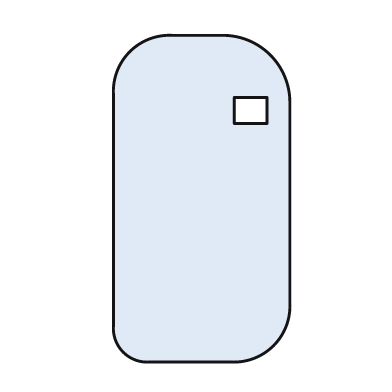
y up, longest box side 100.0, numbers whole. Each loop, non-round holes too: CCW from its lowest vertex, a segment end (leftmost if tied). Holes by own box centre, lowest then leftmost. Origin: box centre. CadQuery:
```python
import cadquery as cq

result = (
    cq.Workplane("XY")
    .moveTo(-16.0, -50.0)
    .lineTo(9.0, -50.0)
    .threePointArc((22.0, -45.0), (27.0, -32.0))
    .lineTo(27.0, 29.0)
    .threePointArc((21.0, 44.0), (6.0, 50.0))
    .lineTo(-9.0, 50.0)
    .threePointArc((-22.0, 45.0), (-27.0, 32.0))
    .lineTo(-27.0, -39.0)
    .threePointArc((-24.0, -47.0), (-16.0, -50.0))
    .close()
    .moveTo(10.0, 23.0)
    .lineTo(20.0, 23.0)
    .lineTo(20.0, 31.0)
    .lineTo(10.0, 31.0)
    .close()
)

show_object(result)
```